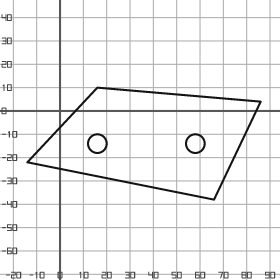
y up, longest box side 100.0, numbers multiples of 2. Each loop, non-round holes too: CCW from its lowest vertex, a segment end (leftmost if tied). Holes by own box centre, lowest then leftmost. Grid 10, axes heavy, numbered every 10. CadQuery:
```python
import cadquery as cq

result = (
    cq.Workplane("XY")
    .moveTo(66.0, -38.0)
    .lineTo(86.0, 4.0)
    .lineTo(16.0, 10.0)
    .lineTo(-14.0, -22.0)
    .close()
    .moveTo(16.0, -14.0)
    .circle(4.0)
    .moveTo(58.0, -14.0)
    .circle(4.0)
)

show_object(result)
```